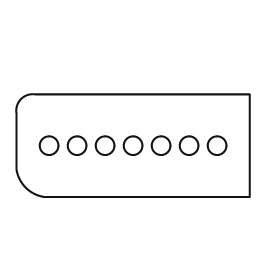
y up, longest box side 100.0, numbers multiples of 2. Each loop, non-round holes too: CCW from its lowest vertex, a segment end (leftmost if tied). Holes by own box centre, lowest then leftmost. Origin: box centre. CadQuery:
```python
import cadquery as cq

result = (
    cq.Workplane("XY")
    .moveTo(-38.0, -22.0)
    .lineTo(50.0, -22.0)
    .lineTo(50.0, 22.0)
    .lineTo(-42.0, 22.0)
    .threePointArc((-48.0, 20.0), (-50.0, 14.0))
    .lineTo(-50.0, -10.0)
    .threePointArc((-46.0, -18.0), (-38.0, -22.0))
    .close()
    .moveTo(-36.0, 0.0)
    .circle(4.0)
    .moveTo(-24.0, 0.0)
    .circle(4.0)
    .moveTo(-12.0, 0.0)
    .circle(4.0)
    .moveTo(0.0, 0.0)
    .circle(4.0)
    .moveTo(12.0, 0.0)
    .circle(4.0)
    .moveTo(24.0, 0.0)
    .circle(4.0)
    .moveTo(36.0, 0.0)
    .circle(4.0)
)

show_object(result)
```